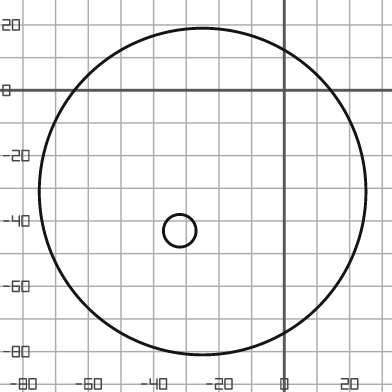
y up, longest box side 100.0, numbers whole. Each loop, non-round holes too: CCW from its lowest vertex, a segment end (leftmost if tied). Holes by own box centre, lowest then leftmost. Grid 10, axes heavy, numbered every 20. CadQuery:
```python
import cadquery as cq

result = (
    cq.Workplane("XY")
    .moveTo(-25.0, -31.0)
    .circle(50.0)
    .moveTo(-32.0, -43.0)
    .circle(5.0)
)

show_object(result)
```